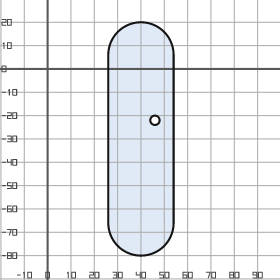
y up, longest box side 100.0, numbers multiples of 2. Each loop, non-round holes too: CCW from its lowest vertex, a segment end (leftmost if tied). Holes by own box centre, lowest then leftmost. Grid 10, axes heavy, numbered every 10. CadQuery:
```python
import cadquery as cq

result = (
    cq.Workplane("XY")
    .moveTo(26.0, -66.0)
    .threePointArc((40.0, -80.0), (54.0, -66.0))
    .lineTo(54.0, 6.0)
    .threePointArc((40.0, 20.0), (26.0, 6.0))
    .close()
    .moveTo(46.0, -22.0)
    .circle(2.0)
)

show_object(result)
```